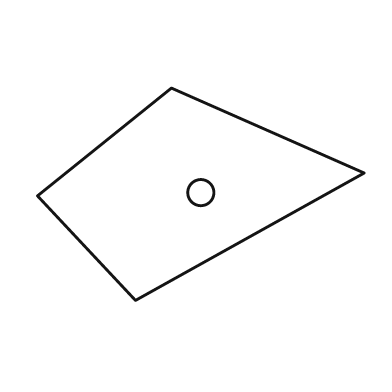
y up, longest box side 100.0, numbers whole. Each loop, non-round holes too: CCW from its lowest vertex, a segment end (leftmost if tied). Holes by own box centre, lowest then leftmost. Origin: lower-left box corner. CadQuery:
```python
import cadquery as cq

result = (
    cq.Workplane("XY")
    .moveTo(30.0, 0.0)
    .lineTo(100.0, 39.0)
    .lineTo(41.0, 65.0)
    .lineTo(0.0, 32.0)
    .close()
    .moveTo(50.0, 33.0)
    .circle(4.0)
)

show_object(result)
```